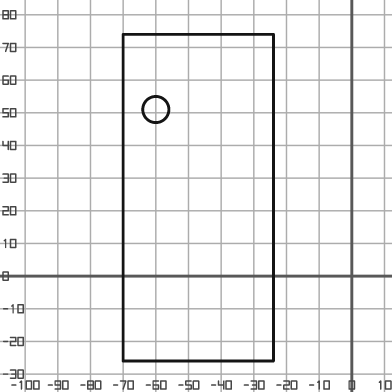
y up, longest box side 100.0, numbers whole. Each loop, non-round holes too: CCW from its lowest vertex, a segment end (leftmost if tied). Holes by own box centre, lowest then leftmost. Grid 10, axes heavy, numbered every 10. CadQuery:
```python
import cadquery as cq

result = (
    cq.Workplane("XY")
    .moveTo(-70.0, -26.0)
    .lineTo(-24.0, -26.0)
    .lineTo(-24.0, 74.0)
    .lineTo(-70.0, 74.0)
    .close()
    .moveTo(-60.0, 51.0)
    .circle(4.0)
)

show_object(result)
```